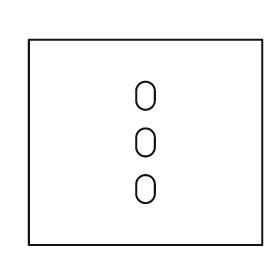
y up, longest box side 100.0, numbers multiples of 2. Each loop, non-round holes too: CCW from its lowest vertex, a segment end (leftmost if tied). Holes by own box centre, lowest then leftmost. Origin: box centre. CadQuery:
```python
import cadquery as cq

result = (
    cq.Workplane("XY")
    .moveTo(-50.0, -44.0)
    .lineTo(50.0, -44.0)
    .lineTo(50.0, 44.0)
    .lineTo(-50.0, 44.0)
    .close()
    .moveTo(-4.0, -22.0)
    .threePointArc((0.0, -26.0), (4.0, -22.0))
    .lineTo(4.0, -18.0)
    .threePointArc((0.0, -14.0), (-4.0, -18.0))
    .close()
    .moveTo(-4.0, -2.0)
    .threePointArc((0.0, -6.0), (4.0, -2.0))
    .lineTo(4.0, 2.0)
    .threePointArc((0.0, 6.0), (-4.0, 2.0))
    .close()
    .moveTo(-4.0, 18.0)
    .threePointArc((0.0, 14.0), (4.0, 18.0))
    .lineTo(4.0, 22.0)
    .threePointArc((0.0, 26.0), (-4.0, 22.0))
    .close()
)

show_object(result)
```